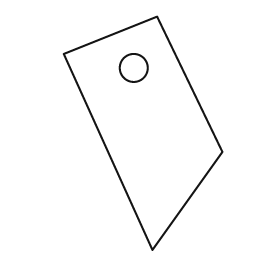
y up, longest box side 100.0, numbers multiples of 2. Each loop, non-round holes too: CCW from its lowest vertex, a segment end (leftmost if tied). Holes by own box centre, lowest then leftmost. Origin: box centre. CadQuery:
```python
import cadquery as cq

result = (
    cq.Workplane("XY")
    .moveTo(4.0, -50.0)
    .lineTo(34.0, -8.0)
    .lineTo(6.0, 50.0)
    .lineTo(-34.0, 34.0)
    .close()
    .moveTo(-4.0, 28.0)
    .circle(6.0)
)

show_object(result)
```